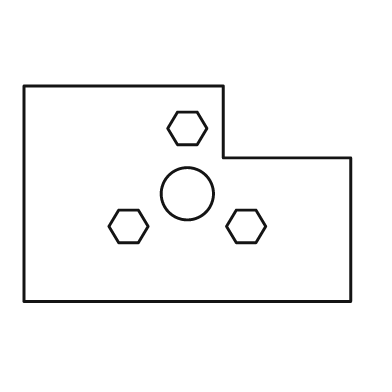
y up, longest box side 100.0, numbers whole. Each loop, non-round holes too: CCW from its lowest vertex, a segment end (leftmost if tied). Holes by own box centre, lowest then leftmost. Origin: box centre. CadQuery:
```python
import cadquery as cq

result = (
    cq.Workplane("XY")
    .moveTo(-50.0, -33.0)
    .lineTo(50.0, -33.0)
    .lineTo(50.0, 11.0)
    .lineTo(11.0, 11.0)
    .lineTo(11.0, 33.0)
    .lineTo(-50.0, 33.0)
    .close()
    .moveTo(-21.0, -15.0)
    .lineTo(-15.0, -15.0)
    .lineTo(-12.0, -10.0)
    .lineTo(-15.0, -5.0)
    .lineTo(-21.0, -5.0)
    .lineTo(-24.0, -10.0)
    .close()
    .moveTo(15.0, -15.0)
    .lineTo(21.0, -15.0)
    .lineTo(24.0, -10.0)
    .lineTo(21.0, -5.0)
    .lineTo(15.0, -5.0)
    .lineTo(12.0, -10.0)
    .close()
    .moveTo(0.0, 0.0)
    .circle(8.0)
    .moveTo(-3.0, 15.0)
    .lineTo(3.0, 15.0)
    .lineTo(6.0, 20.0)
    .lineTo(3.0, 25.0)
    .lineTo(-3.0, 25.0)
    .lineTo(-6.0, 20.0)
    .close()
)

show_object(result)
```